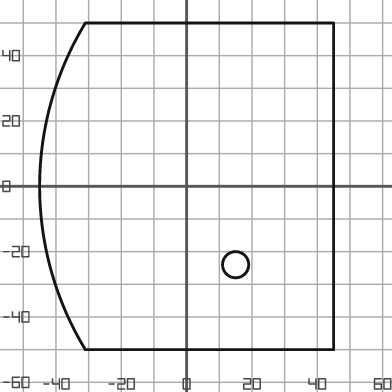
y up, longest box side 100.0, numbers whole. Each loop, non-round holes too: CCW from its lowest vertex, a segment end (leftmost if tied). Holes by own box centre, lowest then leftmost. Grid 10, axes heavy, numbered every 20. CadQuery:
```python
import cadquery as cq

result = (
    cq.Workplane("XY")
    .moveTo(-31.0, -50.0)
    .lineTo(45.0, -50.0)
    .lineTo(45.0, 50.0)
    .lineTo(-31.0, 50.0)
    .threePointArc((-45.0, 0.0), (-31.0, -50.0))
    .close()
    .moveTo(15.0, -24.0)
    .circle(4.0)
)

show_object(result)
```